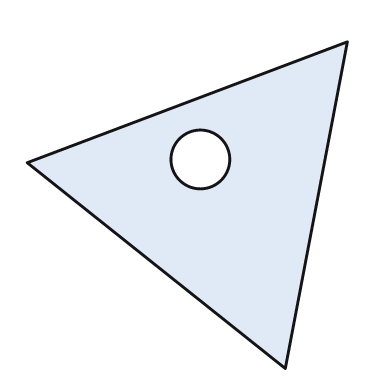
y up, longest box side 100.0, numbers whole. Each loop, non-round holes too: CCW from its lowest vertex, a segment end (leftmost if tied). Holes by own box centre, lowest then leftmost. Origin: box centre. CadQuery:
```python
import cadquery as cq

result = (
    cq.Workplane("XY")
    .moveTo(30.0, -50.0)
    .lineTo(49.0, 50.0)
    .lineTo(-49.0, 13.0)
    .close()
    .moveTo(4.0, 14.0)
    .circle(9.0)
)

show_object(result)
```